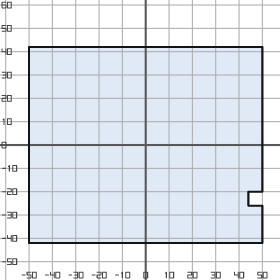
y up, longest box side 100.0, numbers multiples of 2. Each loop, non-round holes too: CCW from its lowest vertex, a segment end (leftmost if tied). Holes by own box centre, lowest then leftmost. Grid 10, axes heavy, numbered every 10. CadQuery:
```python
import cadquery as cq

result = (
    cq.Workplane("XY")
    .moveTo(-50.0, -42.0)
    .lineTo(50.0, -42.0)
    .lineTo(50.0, -26.0)
    .lineTo(44.0, -26.0)
    .lineTo(44.0, -20.0)
    .lineTo(50.0, -20.0)
    .lineTo(50.0, 42.0)
    .lineTo(-50.0, 42.0)
    .close()
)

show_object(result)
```